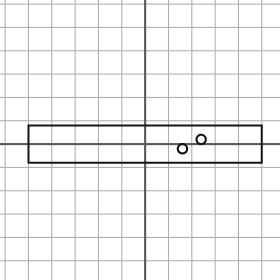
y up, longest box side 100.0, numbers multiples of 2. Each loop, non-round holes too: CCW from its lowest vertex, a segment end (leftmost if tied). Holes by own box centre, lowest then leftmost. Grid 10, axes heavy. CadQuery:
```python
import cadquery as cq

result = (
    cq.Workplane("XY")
    .moveTo(-50.0, -8.0)
    .lineTo(50.0, -8.0)
    .lineTo(50.0, 8.0)
    .lineTo(-50.0, 8.0)
    .close()
    .moveTo(16.0, -2.0)
    .circle(2.0)
    .moveTo(24.0, 2.0)
    .circle(2.0)
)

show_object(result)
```